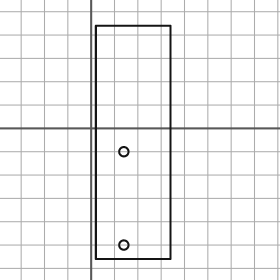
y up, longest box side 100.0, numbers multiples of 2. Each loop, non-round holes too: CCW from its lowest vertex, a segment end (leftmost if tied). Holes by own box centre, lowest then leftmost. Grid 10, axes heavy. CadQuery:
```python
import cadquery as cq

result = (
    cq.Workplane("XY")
    .moveTo(2.0, -56.0)
    .lineTo(34.0, -56.0)
    .lineTo(34.0, 44.0)
    .lineTo(2.0, 44.0)
    .close()
    .moveTo(14.0, -50.0)
    .circle(2.0)
    .moveTo(14.0, -10.0)
    .circle(2.0)
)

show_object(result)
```